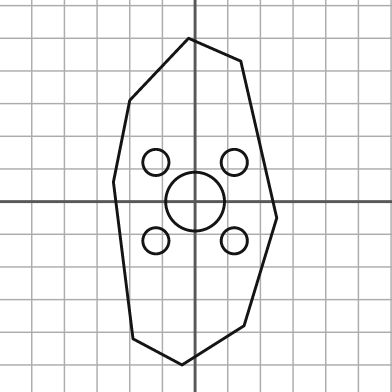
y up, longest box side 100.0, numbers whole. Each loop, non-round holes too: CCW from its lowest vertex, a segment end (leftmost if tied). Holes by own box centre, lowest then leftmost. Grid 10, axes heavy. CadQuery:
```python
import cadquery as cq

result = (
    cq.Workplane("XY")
    .moveTo(-4.0, -50.0)
    .lineTo(15.0, -38.0)
    .lineTo(25.0, -5.0)
    .lineTo(14.0, 43.0)
    .lineTo(-2.0, 50.0)
    .lineTo(-20.0, 31.0)
    .lineTo(-25.0, 6.0)
    .lineTo(-19.0, -42.0)
    .close()
    .moveTo(-12.0, -12.0)
    .circle(4.0)
    .moveTo(12.0, -12.0)
    .circle(4.0)
    .moveTo(0.0, 0.0)
    .circle(9.0)
    .moveTo(-12.0, 12.0)
    .circle(4.0)
    .moveTo(12.0, 12.0)
    .circle(4.0)
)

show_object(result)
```